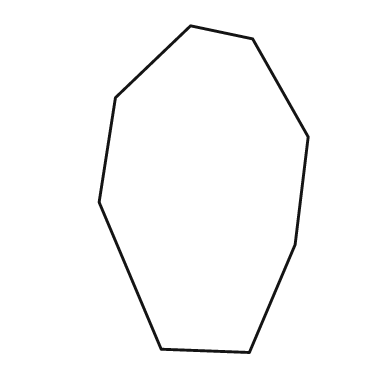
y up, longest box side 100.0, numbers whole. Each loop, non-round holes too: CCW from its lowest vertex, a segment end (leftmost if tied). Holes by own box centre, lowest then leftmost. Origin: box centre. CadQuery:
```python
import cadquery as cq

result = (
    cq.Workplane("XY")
    .moveTo(14.0, -50.0)
    .lineTo(28.0, -17.0)
    .lineTo(32.0, 16.0)
    .lineTo(15.0, 46.0)
    .lineTo(-4.0, 50.0)
    .lineTo(-27.0, 28.0)
    .lineTo(-32.0, -4.0)
    .lineTo(-13.0, -49.0)
    .close()
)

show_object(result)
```